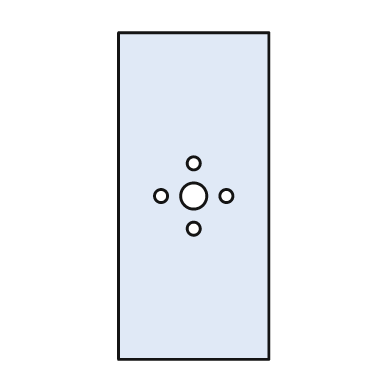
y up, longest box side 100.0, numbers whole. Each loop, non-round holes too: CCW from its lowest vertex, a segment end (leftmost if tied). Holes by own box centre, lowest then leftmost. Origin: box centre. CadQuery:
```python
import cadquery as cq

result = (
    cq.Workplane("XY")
    .moveTo(-23.0, -50.0)
    .lineTo(23.0, -50.0)
    .lineTo(23.0, 50.0)
    .lineTo(-23.0, 50.0)
    .close()
    .moveTo(0.0, -10.0)
    .circle(2.0)
    .moveTo(-10.0, 0.0)
    .circle(2.0)
    .moveTo(0.0, 0.0)
    .circle(4.0)
    .moveTo(10.0, 0.0)
    .circle(2.0)
    .moveTo(0.0, 10.0)
    .circle(2.0)
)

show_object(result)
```